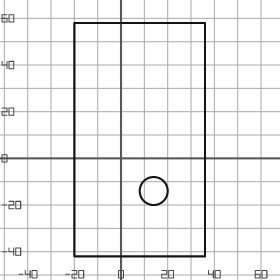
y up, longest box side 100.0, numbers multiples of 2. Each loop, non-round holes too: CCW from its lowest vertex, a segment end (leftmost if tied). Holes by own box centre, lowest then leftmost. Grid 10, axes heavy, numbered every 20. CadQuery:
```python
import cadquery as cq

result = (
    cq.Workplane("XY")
    .moveTo(-20.0, -42.0)
    .lineTo(36.0, -42.0)
    .lineTo(36.0, 58.0)
    .lineTo(-20.0, 58.0)
    .close()
    .moveTo(14.0, -14.0)
    .circle(6.0)
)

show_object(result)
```